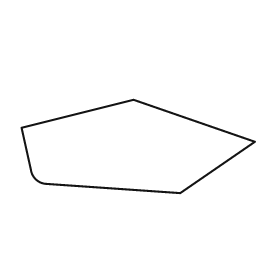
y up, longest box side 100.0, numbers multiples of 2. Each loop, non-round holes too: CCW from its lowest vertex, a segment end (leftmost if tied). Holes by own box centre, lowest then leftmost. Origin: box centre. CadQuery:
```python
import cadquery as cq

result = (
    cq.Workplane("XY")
    .moveTo(18.0, -20.0)
    .lineTo(50.0, 2.0)
    .lineTo(-2.0, 20.0)
    .lineTo(-50.0, 8.0)
    .lineTo(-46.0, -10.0)
    .threePointArc((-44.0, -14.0), (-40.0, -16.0))
    .close()
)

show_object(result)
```